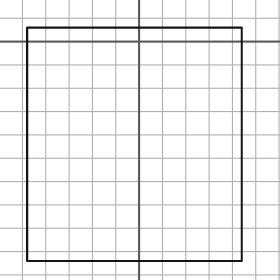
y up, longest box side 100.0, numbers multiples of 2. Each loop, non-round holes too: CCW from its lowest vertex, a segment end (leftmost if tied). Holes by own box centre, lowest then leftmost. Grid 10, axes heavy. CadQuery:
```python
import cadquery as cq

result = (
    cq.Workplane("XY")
    .moveTo(-48.0, -94.0)
    .lineTo(44.0, -94.0)
    .lineTo(44.0, 6.0)
    .lineTo(-48.0, 6.0)
    .close()
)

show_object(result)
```